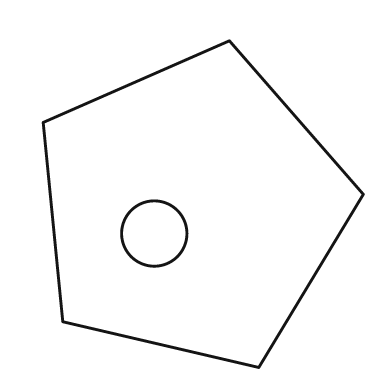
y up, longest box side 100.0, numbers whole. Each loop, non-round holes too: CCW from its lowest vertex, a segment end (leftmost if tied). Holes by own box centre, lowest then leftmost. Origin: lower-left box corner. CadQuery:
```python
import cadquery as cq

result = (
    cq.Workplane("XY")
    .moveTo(66.0, 0.0)
    .lineTo(98.0, 53.0)
    .lineTo(57.0, 100.0)
    .lineTo(0.0, 75.0)
    .lineTo(6.0, 14.0)
    .close()
    .moveTo(34.0, 41.0)
    .circle(10.0)
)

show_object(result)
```